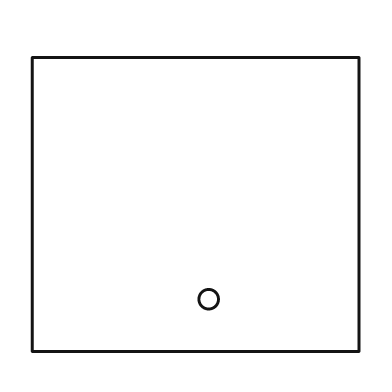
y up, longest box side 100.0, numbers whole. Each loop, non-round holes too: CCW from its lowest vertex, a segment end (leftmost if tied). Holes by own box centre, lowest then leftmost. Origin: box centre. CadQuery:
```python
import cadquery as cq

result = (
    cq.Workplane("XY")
    .moveTo(-50.0, -45.0)
    .lineTo(50.0, -45.0)
    .lineTo(50.0, 45.0)
    .lineTo(-50.0, 45.0)
    .close()
    .moveTo(4.0, -29.0)
    .circle(3.0)
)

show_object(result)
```